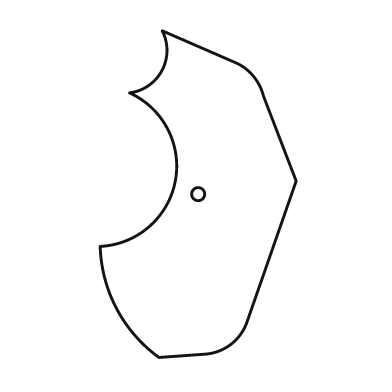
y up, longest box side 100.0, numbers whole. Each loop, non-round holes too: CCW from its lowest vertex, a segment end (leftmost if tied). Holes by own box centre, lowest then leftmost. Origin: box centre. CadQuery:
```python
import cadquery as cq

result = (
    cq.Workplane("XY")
    .moveTo(-12.0, -50.0)
    .lineTo(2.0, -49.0)
    .threePointArc((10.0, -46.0), (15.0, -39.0))
    .lineTo(30.0, 4.0)
    .lineTo(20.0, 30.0)
    .threePointArc((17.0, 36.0), (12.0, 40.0))
    .lineTo(-11.0, 50.0)
    .threePointArc((-11.0, 38.0), (-21.0, 31.0))
    .threePointArc((-7.0, 4.0), (-30.0, -16.0))
    .threePointArc((-25.0, -35.0), (-12.0, -50.0))
    .close()
    .moveTo(0.0, 0.0)
    .circle(2.0)
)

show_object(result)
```